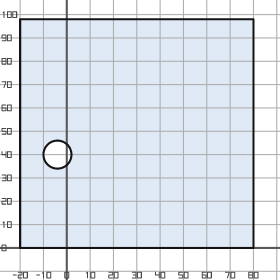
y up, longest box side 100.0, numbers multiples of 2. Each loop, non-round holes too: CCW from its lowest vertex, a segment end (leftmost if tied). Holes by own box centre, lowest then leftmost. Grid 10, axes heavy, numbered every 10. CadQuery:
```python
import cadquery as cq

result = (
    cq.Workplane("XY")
    .moveTo(-20.0, 0.0)
    .lineTo(80.0, 0.0)
    .lineTo(80.0, 98.0)
    .lineTo(-20.0, 98.0)
    .close()
    .moveTo(-4.0, 40.0)
    .circle(6.0)
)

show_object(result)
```